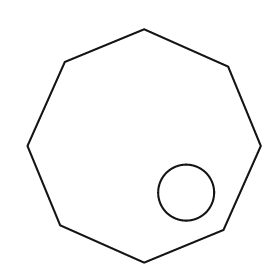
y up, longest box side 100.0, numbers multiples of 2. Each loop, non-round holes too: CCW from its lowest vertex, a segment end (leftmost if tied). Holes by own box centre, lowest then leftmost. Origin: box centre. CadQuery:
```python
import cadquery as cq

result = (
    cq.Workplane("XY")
    .moveTo(0.0, -50.0)
    .lineTo(34.0, -36.0)
    .lineTo(50.0, 0.0)
    .lineTo(36.0, 34.0)
    .lineTo(0.0, 50.0)
    .lineTo(-34.0, 36.0)
    .lineTo(-50.0, 0.0)
    .lineTo(-36.0, -34.0)
    .close()
    .moveTo(18.0, -20.0)
    .circle(12.0)
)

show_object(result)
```